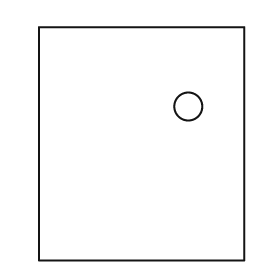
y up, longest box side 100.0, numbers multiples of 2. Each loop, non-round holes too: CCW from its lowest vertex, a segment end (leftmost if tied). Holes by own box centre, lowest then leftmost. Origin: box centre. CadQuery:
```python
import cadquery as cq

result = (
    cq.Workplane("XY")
    .moveTo(-44.0, -50.0)
    .lineTo(44.0, -50.0)
    .lineTo(44.0, 50.0)
    .lineTo(-44.0, 50.0)
    .close()
    .moveTo(20.0, 16.0)
    .circle(6.0)
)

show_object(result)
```